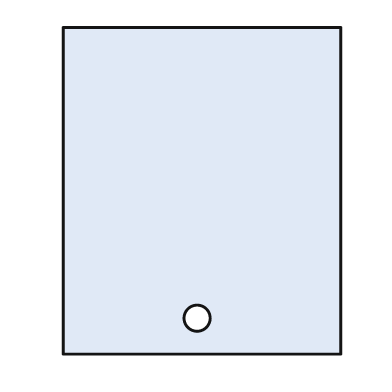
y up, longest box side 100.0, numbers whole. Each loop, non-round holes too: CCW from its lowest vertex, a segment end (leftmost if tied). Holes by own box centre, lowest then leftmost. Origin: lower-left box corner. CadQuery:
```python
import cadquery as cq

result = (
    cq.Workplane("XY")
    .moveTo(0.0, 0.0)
    .lineTo(85.0, 0.0)
    .lineTo(85.0, 100.0)
    .lineTo(0.0, 100.0)
    .close()
    .moveTo(41.0, 11.0)
    .circle(4.0)
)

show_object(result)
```